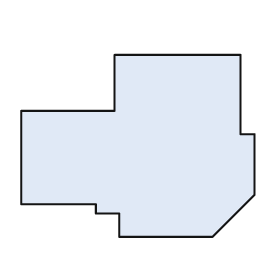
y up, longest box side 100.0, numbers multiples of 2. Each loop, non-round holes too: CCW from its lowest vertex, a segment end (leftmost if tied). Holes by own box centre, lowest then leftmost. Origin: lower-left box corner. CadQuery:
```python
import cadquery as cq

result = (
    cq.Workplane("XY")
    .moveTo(42.0, 0.0)
    .lineTo(82.0, 0.0)
    .lineTo(100.0, 18.0)
    .lineTo(100.0, 44.0)
    .lineTo(94.0, 44.0)
    .lineTo(94.0, 78.0)
    .lineTo(40.0, 78.0)
    .lineTo(40.0, 54.0)
    .lineTo(0.0, 54.0)
    .lineTo(0.0, 14.0)
    .lineTo(32.0, 14.0)
    .lineTo(32.0, 10.0)
    .lineTo(42.0, 10.0)
    .close()
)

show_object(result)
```